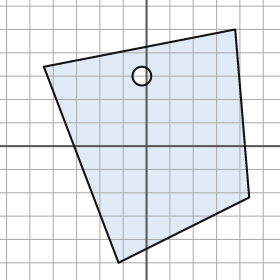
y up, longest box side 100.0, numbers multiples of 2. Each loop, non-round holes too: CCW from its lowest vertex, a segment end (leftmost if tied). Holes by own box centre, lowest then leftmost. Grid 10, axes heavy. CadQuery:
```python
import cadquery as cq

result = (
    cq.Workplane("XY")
    .moveTo(-12.0, -50.0)
    .lineTo(44.0, -22.0)
    .lineTo(38.0, 50.0)
    .lineTo(-44.0, 34.0)
    .close()
    .moveTo(-2.0, 30.0)
    .circle(4.0)
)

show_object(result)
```